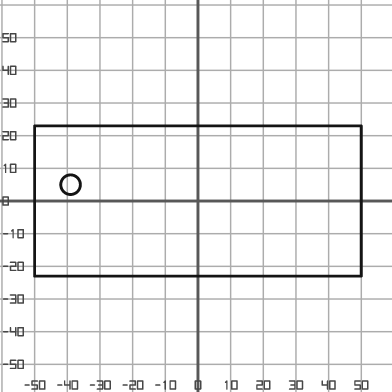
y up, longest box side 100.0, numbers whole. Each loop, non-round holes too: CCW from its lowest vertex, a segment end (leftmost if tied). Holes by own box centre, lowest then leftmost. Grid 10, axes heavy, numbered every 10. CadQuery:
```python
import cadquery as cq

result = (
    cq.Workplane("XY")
    .moveTo(-50.0, -23.0)
    .lineTo(50.0, -23.0)
    .lineTo(50.0, 23.0)
    .lineTo(-50.0, 23.0)
    .close()
    .moveTo(-39.0, 5.0)
    .circle(3.0)
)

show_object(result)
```